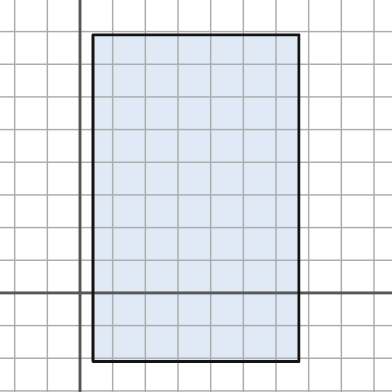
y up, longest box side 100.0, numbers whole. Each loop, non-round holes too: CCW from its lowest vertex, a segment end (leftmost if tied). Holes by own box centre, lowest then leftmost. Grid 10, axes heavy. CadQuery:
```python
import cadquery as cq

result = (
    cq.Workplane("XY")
    .moveTo(4.0, -21.0)
    .lineTo(67.0, -21.0)
    .lineTo(67.0, 79.0)
    .lineTo(4.0, 79.0)
    .close()
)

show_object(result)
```